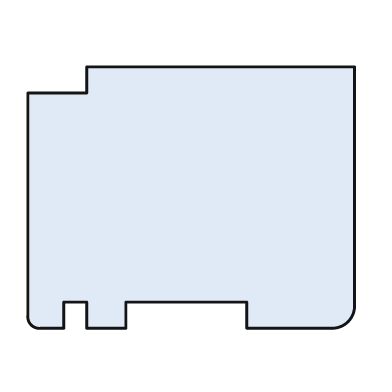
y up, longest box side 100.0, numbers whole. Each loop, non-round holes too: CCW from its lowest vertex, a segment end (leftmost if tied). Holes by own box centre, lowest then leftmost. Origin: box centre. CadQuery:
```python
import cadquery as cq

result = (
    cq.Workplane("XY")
    .moveTo(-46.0, -40.0)
    .lineTo(-39.0, -40.0)
    .lineTo(-39.0, -32.0)
    .lineTo(-32.0, -32.0)
    .lineTo(-32.0, -40.0)
    .lineTo(-20.0, -40.0)
    .lineTo(-20.0, -32.0)
    .lineTo(17.0, -32.0)
    .lineTo(17.0, -40.0)
    .lineTo(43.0, -40.0)
    .threePointArc((48.0, -38.0), (50.0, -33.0))
    .lineTo(50.0, 40.0)
    .lineTo(-32.0, 40.0)
    .lineTo(-32.0, 32.0)
    .lineTo(-50.0, 32.0)
    .lineTo(-50.0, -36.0)
    .threePointArc((-49.0, -39.0), (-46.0, -40.0))
    .close()
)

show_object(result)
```